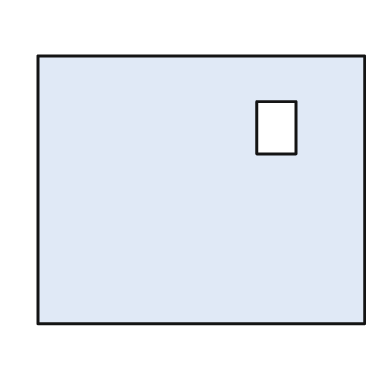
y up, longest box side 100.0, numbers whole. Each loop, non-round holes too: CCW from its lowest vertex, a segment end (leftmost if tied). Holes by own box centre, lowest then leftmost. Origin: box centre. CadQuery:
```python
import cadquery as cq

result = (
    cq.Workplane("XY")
    .moveTo(-50.0, -41.0)
    .lineTo(50.0, -41.0)
    .lineTo(50.0, 41.0)
    .lineTo(-50.0, 41.0)
    .close()
    .moveTo(17.0, 11.0)
    .lineTo(29.0, 11.0)
    .lineTo(29.0, 27.0)
    .lineTo(17.0, 27.0)
    .close()
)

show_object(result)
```